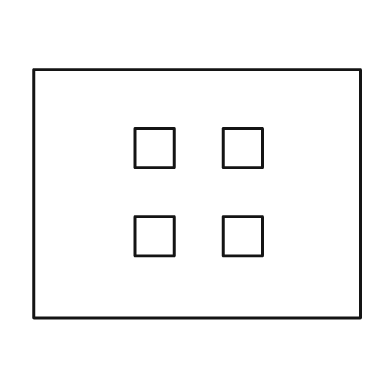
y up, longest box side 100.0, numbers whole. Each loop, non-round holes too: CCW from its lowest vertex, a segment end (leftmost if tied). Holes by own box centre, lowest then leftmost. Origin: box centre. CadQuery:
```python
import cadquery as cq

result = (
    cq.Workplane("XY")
    .moveTo(-50.0, -38.0)
    .lineTo(50.0, -38.0)
    .lineTo(50.0, 38.0)
    .lineTo(-50.0, 38.0)
    .close()
    .moveTo(-19.0, -19.0)
    .lineTo(-7.0, -19.0)
    .lineTo(-7.0, -7.0)
    .lineTo(-19.0, -7.0)
    .close()
    .moveTo(8.0, -19.0)
    .lineTo(20.0, -19.0)
    .lineTo(20.0, -7.0)
    .lineTo(8.0, -7.0)
    .close()
    .moveTo(-19.0, 8.0)
    .lineTo(-7.0, 8.0)
    .lineTo(-7.0, 20.0)
    .lineTo(-19.0, 20.0)
    .close()
    .moveTo(8.0, 8.0)
    .lineTo(20.0, 8.0)
    .lineTo(20.0, 20.0)
    .lineTo(8.0, 20.0)
    .close()
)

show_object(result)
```